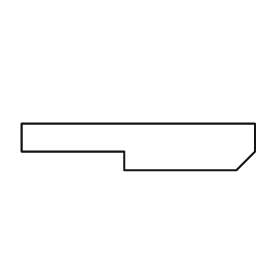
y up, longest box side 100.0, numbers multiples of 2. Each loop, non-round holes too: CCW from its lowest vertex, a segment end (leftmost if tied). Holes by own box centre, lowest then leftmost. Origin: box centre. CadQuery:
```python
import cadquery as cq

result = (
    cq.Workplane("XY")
    .moveTo(-6.0, -10.0)
    .lineTo(42.0, -10.0)
    .lineTo(50.0, -2.0)
    .lineTo(50.0, 10.0)
    .lineTo(-50.0, 10.0)
    .lineTo(-50.0, -2.0)
    .lineTo(-6.0, -2.0)
    .close()
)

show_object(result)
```